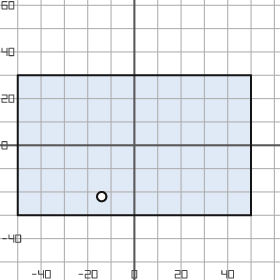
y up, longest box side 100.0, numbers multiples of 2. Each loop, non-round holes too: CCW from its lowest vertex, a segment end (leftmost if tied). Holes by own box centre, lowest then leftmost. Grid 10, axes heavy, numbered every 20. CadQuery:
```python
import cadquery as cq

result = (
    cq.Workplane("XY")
    .moveTo(-50.0, -30.0)
    .lineTo(50.0, -30.0)
    .lineTo(50.0, 30.0)
    .lineTo(-50.0, 30.0)
    .close()
    .moveTo(-14.0, -22.0)
    .circle(2.0)
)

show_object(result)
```